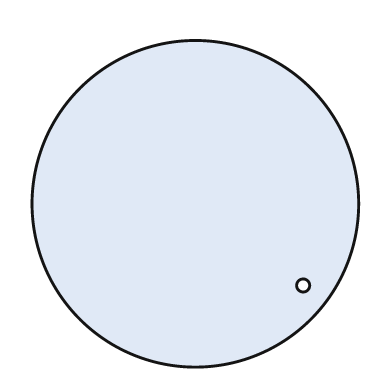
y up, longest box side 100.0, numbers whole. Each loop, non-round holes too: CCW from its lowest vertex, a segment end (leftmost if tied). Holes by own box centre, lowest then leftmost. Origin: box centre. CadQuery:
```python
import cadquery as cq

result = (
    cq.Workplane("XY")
    .moveTo(0.0, 0.0)
    .circle(50.0)
    .moveTo(33.0, -25.0)
    .circle(2.0)
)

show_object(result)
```